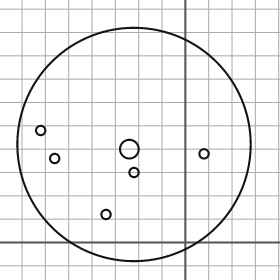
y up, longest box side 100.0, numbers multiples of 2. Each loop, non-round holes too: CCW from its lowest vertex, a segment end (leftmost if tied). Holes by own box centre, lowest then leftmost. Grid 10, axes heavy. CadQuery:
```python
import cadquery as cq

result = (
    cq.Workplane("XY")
    .moveTo(-22.0, 42.0)
    .circle(50.0)
    .moveTo(-34.0, 12.0)
    .circle(2.0)
    .moveTo(-22.0, 30.0)
    .circle(2.0)
    .moveTo(-56.0, 36.0)
    .circle(2.0)
    .moveTo(8.0, 38.0)
    .circle(2.0)
    .moveTo(-24.0, 40.0)
    .circle(4.0)
    .moveTo(-62.0, 48.0)
    .circle(2.0)
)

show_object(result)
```